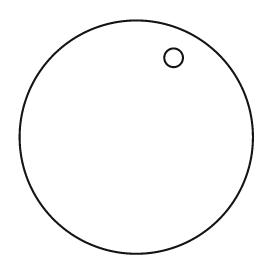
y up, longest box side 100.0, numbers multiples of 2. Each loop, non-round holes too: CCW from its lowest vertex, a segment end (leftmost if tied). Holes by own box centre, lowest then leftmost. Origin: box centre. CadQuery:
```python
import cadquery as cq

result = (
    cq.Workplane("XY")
    .moveTo(0.0, 0.0)
    .circle(50.0)
    .moveTo(16.0, 34.0)
    .circle(4.0)
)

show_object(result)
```